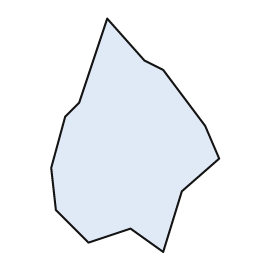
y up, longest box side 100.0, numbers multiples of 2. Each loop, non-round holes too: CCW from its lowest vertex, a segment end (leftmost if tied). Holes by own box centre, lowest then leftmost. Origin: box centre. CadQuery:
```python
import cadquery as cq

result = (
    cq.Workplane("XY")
    .moveTo(12.0, -50.0)
    .lineTo(20.0, -24.0)
    .lineTo(36.0, -10.0)
    .lineTo(30.0, 4.0)
    .lineTo(12.0, 28.0)
    .lineTo(4.0, 32.0)
    .lineTo(-12.0, 50.0)
    .lineTo(-24.0, 14.0)
    .lineTo(-30.0, 8.0)
    .lineTo(-36.0, -14.0)
    .lineTo(-34.0, -32.0)
    .lineTo(-20.0, -46.0)
    .lineTo(-2.0, -40.0)
    .close()
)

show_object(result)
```